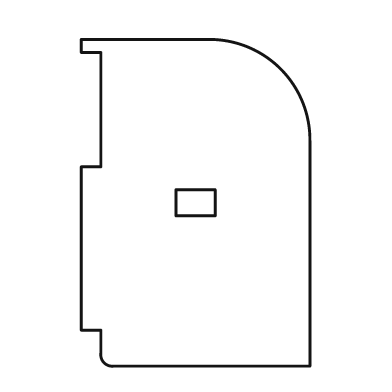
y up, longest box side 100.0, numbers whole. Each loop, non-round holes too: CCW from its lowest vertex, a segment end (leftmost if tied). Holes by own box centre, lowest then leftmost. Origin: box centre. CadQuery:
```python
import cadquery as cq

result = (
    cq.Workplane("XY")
    .moveTo(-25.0, -50.0)
    .lineTo(35.0, -50.0)
    .lineTo(35.0, 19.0)
    .threePointArc((26.0, 41.0), (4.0, 50.0))
    .lineTo(-35.0, 50.0)
    .lineTo(-35.0, 46.0)
    .lineTo(-29.0, 46.0)
    .lineTo(-29.0, 11.0)
    .lineTo(-35.0, 11.0)
    .lineTo(-35.0, -39.0)
    .lineTo(-29.0, -39.0)
    .lineTo(-29.0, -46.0)
    .threePointArc((-28.0, -49.0), (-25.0, -50.0))
    .close()
    .moveTo(-6.0, -4.0)
    .lineTo(6.0, -4.0)
    .lineTo(6.0, 4.0)
    .lineTo(-6.0, 4.0)
    .close()
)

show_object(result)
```